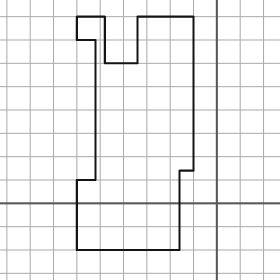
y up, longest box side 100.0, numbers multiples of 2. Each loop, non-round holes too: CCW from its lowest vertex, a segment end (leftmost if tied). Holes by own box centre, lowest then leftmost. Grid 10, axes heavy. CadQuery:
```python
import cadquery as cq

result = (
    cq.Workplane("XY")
    .moveTo(-60.0, -20.0)
    .lineTo(-16.0, -20.0)
    .lineTo(-16.0, 14.0)
    .lineTo(-10.0, 14.0)
    .lineTo(-10.0, 80.0)
    .lineTo(-34.0, 80.0)
    .lineTo(-34.0, 60.0)
    .lineTo(-48.0, 60.0)
    .lineTo(-48.0, 80.0)
    .lineTo(-60.0, 80.0)
    .lineTo(-60.0, 70.0)
    .lineTo(-52.0, 70.0)
    .lineTo(-52.0, 10.0)
    .lineTo(-60.0, 10.0)
    .close()
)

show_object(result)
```